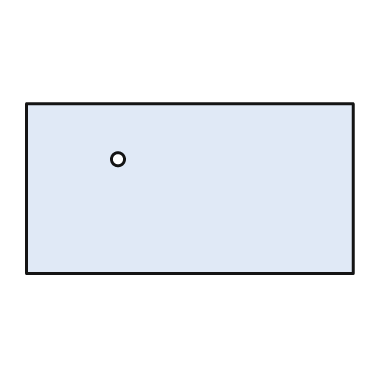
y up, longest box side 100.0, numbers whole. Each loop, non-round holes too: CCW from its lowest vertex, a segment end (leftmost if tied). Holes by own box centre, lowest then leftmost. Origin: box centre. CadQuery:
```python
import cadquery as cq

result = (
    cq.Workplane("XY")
    .moveTo(-50.0, -26.0)
    .lineTo(50.0, -26.0)
    .lineTo(50.0, 26.0)
    .lineTo(-50.0, 26.0)
    .close()
    .moveTo(-22.0, 9.0)
    .circle(2.0)
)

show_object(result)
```